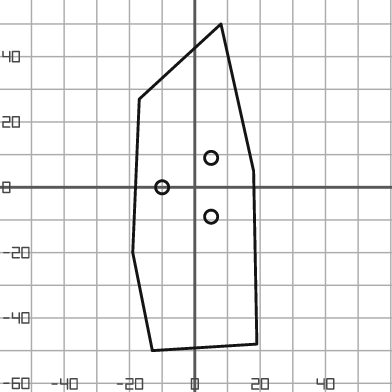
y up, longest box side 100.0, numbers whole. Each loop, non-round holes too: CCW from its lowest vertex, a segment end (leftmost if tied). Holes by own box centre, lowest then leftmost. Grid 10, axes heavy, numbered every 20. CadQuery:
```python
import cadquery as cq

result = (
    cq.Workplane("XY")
    .moveTo(-13.0, -50.0)
    .lineTo(19.0, -48.0)
    .lineTo(18.0, 5.0)
    .lineTo(8.0, 50.0)
    .lineTo(-17.0, 27.0)
    .lineTo(-19.0, -20.0)
    .close()
    .moveTo(5.0, -9.0)
    .circle(2.0)
    .moveTo(-10.0, 0.0)
    .circle(2.0)
    .moveTo(5.0, 9.0)
    .circle(2.0)
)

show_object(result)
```